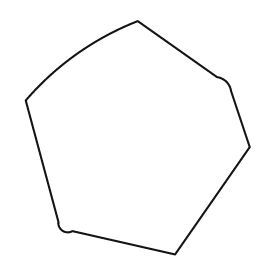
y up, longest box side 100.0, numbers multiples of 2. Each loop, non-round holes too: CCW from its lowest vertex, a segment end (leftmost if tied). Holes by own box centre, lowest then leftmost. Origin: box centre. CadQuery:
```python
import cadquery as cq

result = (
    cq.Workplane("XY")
    .moveTo(16.0, -50.0)
    .lineTo(48.0, -4.0)
    .lineTo(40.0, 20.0)
    .threePointArc((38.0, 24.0), (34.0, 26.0))
    .lineTo(0.0, 50.0)
    .threePointArc((-26.0, 36.0), (-48.0, 16.0))
    .lineTo(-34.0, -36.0)
    .threePointArc((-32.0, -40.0), (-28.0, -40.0))
    .close()
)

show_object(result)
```